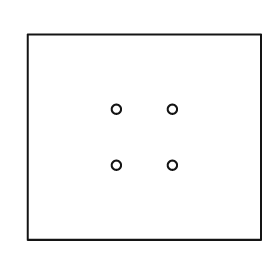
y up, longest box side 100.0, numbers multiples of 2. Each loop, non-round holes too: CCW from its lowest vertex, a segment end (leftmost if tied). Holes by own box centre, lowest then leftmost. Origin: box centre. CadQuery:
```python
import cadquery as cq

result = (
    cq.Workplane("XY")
    .moveTo(-50.0, -44.0)
    .lineTo(50.0, -44.0)
    .lineTo(50.0, 44.0)
    .lineTo(-50.0, 44.0)
    .close()
    .moveTo(-12.0, -12.0)
    .circle(2.0)
    .moveTo(12.0, -12.0)
    .circle(2.0)
    .moveTo(-12.0, 12.0)
    .circle(2.0)
    .moveTo(12.0, 12.0)
    .circle(2.0)
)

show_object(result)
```